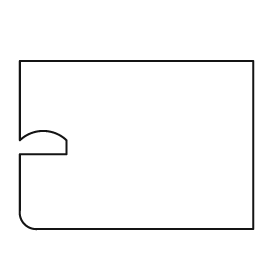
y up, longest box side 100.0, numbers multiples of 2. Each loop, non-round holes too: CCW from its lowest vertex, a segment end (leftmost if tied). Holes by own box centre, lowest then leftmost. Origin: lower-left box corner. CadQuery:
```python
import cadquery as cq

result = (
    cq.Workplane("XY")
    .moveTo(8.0, 0.0)
    .lineTo(100.0, 0.0)
    .lineTo(100.0, 72.0)
    .lineTo(0.0, 72.0)
    .lineTo(0.0, 38.0)
    .threePointArc((10.0, 42.0), (20.0, 38.0))
    .lineTo(20.0, 32.0)
    .lineTo(0.0, 32.0)
    .lineTo(0.0, 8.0)
    .threePointArc((2.0, 2.0), (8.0, 0.0))
    .close()
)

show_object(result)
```